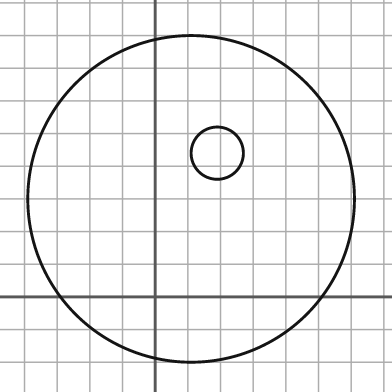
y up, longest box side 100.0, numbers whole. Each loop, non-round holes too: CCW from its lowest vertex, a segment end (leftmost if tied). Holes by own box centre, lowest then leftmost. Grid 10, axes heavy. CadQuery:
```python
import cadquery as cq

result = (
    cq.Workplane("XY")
    .moveTo(11.0, 30.0)
    .circle(50.0)
    .moveTo(19.0, 44.0)
    .circle(8.0)
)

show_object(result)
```